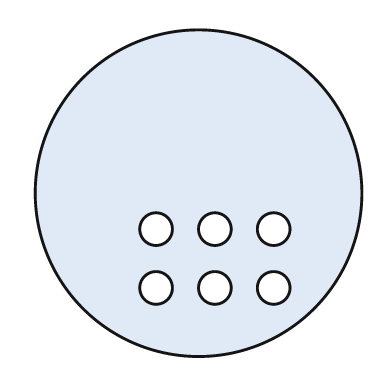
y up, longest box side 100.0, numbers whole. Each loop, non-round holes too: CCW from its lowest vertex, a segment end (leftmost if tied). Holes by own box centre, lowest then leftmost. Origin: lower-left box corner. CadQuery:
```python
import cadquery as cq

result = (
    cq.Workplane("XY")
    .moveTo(50.0, 50.0)
    .circle(50.0)
    .moveTo(37.0, 21.0)
    .circle(5.0)
    .moveTo(55.0, 21.0)
    .circle(5.0)
    .moveTo(73.0, 21.0)
    .circle(5.0)
    .moveTo(37.0, 39.0)
    .circle(5.0)
    .moveTo(55.0, 39.0)
    .circle(5.0)
    .moveTo(73.0, 39.0)
    .circle(5.0)
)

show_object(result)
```